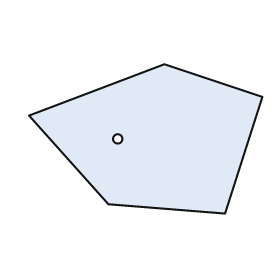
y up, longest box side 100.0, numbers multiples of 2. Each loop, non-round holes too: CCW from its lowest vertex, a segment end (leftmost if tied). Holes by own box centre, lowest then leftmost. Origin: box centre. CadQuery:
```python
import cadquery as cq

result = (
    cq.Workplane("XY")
    .moveTo(34.0, -32.0)
    .lineTo(50.0, 18.0)
    .lineTo(8.0, 32.0)
    .lineTo(-50.0, 10.0)
    .lineTo(-16.0, -28.0)
    .close()
    .moveTo(-12.0, 0.0)
    .circle(2.0)
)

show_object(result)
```